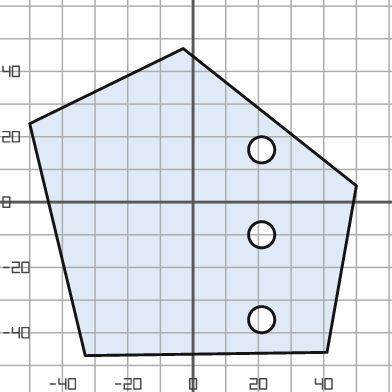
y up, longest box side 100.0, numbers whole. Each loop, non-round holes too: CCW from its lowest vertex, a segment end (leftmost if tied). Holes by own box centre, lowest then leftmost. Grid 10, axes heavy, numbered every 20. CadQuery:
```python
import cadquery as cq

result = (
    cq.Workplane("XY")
    .moveTo(-33.0, -47.0)
    .lineTo(41.0, -46.0)
    .lineTo(50.0, 5.0)
    .lineTo(-3.0, 47.0)
    .lineTo(-50.0, 24.0)
    .close()
    .moveTo(21.0, -36.0)
    .circle(4.0)
    .moveTo(21.0, -10.0)
    .circle(4.0)
    .moveTo(21.0, 16.0)
    .circle(4.0)
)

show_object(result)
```